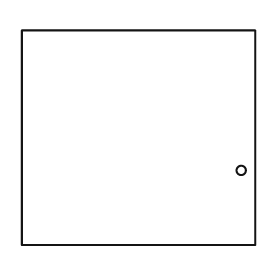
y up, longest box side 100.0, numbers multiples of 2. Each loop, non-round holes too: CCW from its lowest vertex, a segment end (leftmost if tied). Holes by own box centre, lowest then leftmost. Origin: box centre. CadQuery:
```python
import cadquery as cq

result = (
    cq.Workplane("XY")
    .moveTo(-50.0, -46.0)
    .lineTo(50.0, -46.0)
    .lineTo(50.0, 46.0)
    .lineTo(-50.0, 46.0)
    .close()
    .moveTo(44.0, -14.0)
    .circle(2.0)
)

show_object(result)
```